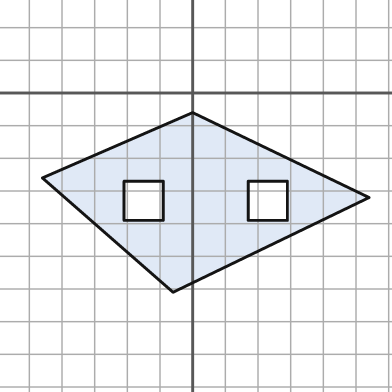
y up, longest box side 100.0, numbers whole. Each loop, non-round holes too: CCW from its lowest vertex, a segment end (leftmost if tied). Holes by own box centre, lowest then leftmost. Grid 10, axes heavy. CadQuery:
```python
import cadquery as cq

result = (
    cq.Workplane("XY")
    .moveTo(-6.0, -61.0)
    .lineTo(54.0, -32.0)
    .lineTo(0.0, -6.0)
    .lineTo(-46.0, -26.0)
    .close()
    .moveTo(-21.0, -39.0)
    .lineTo(-9.0, -39.0)
    .lineTo(-9.0, -27.0)
    .lineTo(-21.0, -27.0)
    .close()
    .moveTo(17.0, -39.0)
    .lineTo(29.0, -39.0)
    .lineTo(29.0, -27.0)
    .lineTo(17.0, -27.0)
    .close()
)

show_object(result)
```